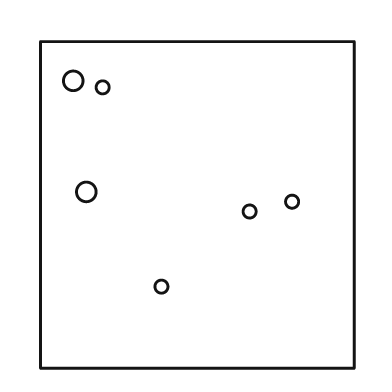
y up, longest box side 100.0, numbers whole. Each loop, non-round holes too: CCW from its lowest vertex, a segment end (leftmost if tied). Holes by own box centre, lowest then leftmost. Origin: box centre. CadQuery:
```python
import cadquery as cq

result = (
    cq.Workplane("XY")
    .moveTo(-48.0, -50.0)
    .lineTo(48.0, -50.0)
    .lineTo(48.0, 50.0)
    .lineTo(-48.0, 50.0)
    .close()
    .moveTo(-11.0, -25.0)
    .circle(2.0)
    .moveTo(16.0, -2.0)
    .circle(2.0)
    .moveTo(29.0, 1.0)
    .circle(2.0)
    .moveTo(-34.0, 4.0)
    .circle(3.0)
    .moveTo(-29.0, 36.0)
    .circle(2.0)
    .moveTo(-38.0, 38.0)
    .circle(3.0)
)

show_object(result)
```